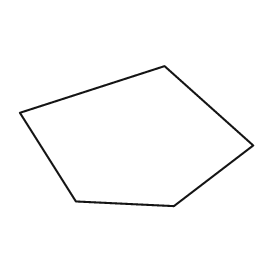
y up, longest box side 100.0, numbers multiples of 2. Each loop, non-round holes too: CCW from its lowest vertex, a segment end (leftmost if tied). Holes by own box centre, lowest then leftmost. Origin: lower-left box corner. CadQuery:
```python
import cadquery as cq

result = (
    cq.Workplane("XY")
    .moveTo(66.0, 0.0)
    .lineTo(100.0, 26.0)
    .lineTo(62.0, 60.0)
    .lineTo(0.0, 40.0)
    .lineTo(24.0, 2.0)
    .close()
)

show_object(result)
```